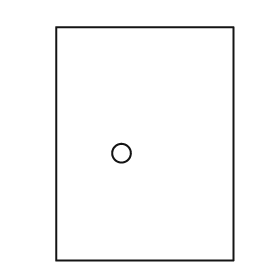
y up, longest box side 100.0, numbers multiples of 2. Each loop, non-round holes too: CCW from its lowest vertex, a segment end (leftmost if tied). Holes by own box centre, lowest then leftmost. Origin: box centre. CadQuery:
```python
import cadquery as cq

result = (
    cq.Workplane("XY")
    .moveTo(-38.0, -50.0)
    .lineTo(38.0, -50.0)
    .lineTo(38.0, 50.0)
    .lineTo(-38.0, 50.0)
    .close()
    .moveTo(-10.0, -4.0)
    .circle(4.0)
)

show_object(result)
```